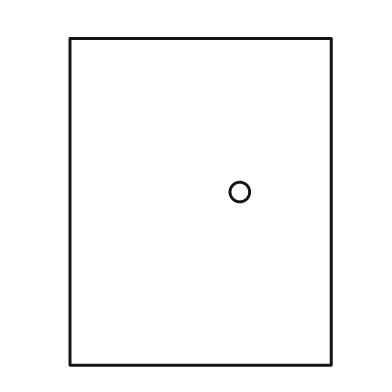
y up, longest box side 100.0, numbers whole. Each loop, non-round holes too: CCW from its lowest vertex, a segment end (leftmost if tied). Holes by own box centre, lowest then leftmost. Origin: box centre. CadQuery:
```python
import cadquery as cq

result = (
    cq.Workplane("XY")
    .moveTo(-40.0, -50.0)
    .lineTo(40.0, -50.0)
    .lineTo(40.0, 50.0)
    .lineTo(-40.0, 50.0)
    .close()
    .moveTo(12.0, 3.0)
    .circle(3.0)
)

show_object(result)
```